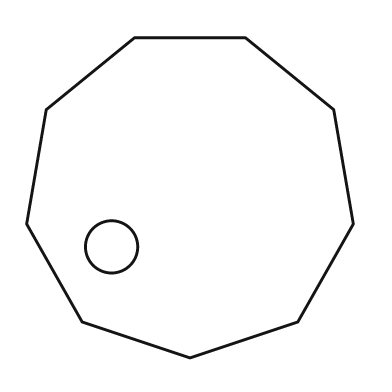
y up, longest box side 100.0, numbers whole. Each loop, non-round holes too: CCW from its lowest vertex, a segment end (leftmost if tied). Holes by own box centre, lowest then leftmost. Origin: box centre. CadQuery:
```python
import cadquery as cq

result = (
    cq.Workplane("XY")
    .moveTo(0.0, -49.0)
    .lineTo(33.0, -38.0)
    .lineTo(50.0, -8.0)
    .lineTo(44.0, 27.0)
    .lineTo(17.0, 49.0)
    .lineTo(-17.0, 49.0)
    .lineTo(-44.0, 27.0)
    .lineTo(-50.0, -8.0)
    .lineTo(-33.0, -38.0)
    .close()
    .moveTo(-24.0, -15.0)
    .circle(8.0)
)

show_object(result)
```